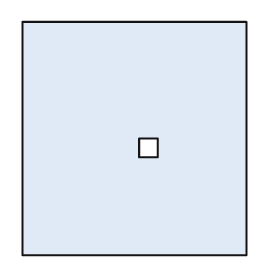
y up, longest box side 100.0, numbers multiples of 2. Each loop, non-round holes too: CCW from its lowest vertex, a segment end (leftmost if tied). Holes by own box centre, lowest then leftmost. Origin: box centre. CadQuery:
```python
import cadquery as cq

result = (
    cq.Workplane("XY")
    .moveTo(-48.0, -50.0)
    .lineTo(48.0, -50.0)
    .lineTo(48.0, 50.0)
    .lineTo(-48.0, 50.0)
    .close()
    .moveTo(2.0, -8.0)
    .lineTo(10.0, -8.0)
    .lineTo(10.0, 0.0)
    .lineTo(2.0, 0.0)
    .close()
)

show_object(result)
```